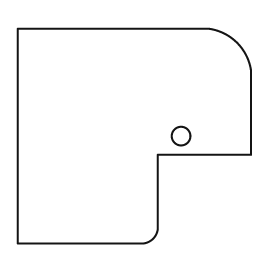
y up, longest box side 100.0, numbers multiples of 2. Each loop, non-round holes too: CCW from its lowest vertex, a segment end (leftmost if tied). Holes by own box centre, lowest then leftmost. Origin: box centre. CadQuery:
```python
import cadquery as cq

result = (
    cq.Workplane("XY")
    .moveTo(-50.0, -46.0)
    .lineTo(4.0, -46.0)
    .threePointArc((8.0, -44.0), (10.0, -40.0))
    .lineTo(10.0, -8.0)
    .lineTo(50.0, -8.0)
    .lineTo(50.0, 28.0)
    .threePointArc((44.0, 40.0), (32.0, 46.0))
    .lineTo(-50.0, 46.0)
    .close()
    .moveTo(20.0, 0.0)
    .circle(4.0)
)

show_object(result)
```